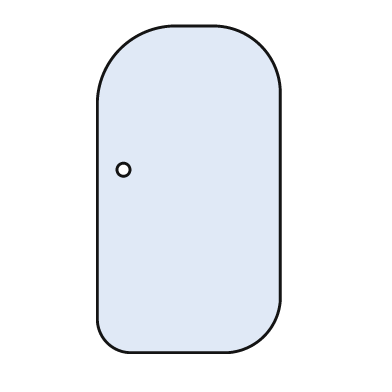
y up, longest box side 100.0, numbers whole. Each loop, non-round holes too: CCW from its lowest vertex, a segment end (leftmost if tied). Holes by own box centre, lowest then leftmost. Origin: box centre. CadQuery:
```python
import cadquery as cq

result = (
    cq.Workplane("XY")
    .moveTo(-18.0, -50.0)
    .lineTo(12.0, -50.0)
    .threePointArc((23.0, -45.0), (28.0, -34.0))
    .lineTo(28.0, 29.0)
    .threePointArc((22.0, 44.0), (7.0, 50.0))
    .lineTo(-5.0, 50.0)
    .threePointArc((-21.0, 43.0), (-28.0, 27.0))
    .lineTo(-28.0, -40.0)
    .threePointArc((-25.0, -47.0), (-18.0, -50.0))
    .close()
    .moveTo(-20.0, 6.0)
    .circle(2.0)
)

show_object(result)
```